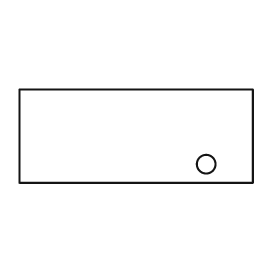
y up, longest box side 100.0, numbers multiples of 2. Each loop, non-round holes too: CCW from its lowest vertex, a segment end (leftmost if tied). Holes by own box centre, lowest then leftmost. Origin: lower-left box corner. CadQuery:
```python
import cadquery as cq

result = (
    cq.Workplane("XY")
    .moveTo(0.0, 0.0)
    .lineTo(100.0, 0.0)
    .lineTo(100.0, 40.0)
    .lineTo(0.0, 40.0)
    .close()
    .moveTo(80.0, 8.0)
    .circle(4.0)
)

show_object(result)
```